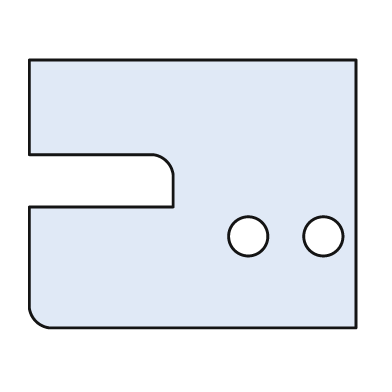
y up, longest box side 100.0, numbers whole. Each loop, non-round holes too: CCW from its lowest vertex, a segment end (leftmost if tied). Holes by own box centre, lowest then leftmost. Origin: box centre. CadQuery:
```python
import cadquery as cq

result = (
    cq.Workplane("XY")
    .moveTo(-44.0, -41.0)
    .lineTo(50.0, -41.0)
    .lineTo(50.0, 41.0)
    .lineTo(-50.0, 41.0)
    .lineTo(-50.0, 12.0)
    .lineTo(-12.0, 12.0)
    .threePointArc((-8.0, 10.0), (-6.0, 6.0))
    .lineTo(-6.0, -4.0)
    .lineTo(-50.0, -4.0)
    .lineTo(-50.0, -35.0)
    .threePointArc((-48.0, -39.0), (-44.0, -41.0))
    .close()
    .moveTo(17.0, -13.0)
    .circle(6.0)
    .moveTo(40.0, -13.0)
    .circle(6.0)
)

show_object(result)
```